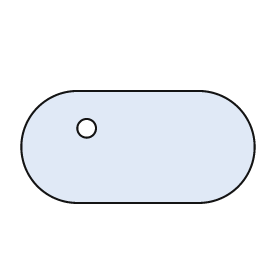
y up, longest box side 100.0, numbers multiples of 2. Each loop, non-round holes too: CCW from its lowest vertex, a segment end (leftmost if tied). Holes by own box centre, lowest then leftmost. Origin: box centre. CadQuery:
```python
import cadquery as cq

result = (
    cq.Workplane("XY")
    .moveTo(-26.0, -24.0)
    .lineTo(26.0, -24.0)
    .threePointArc((50.0, 0.0), (26.0, 24.0))
    .lineTo(-26.0, 24.0)
    .threePointArc((-50.0, 0.0), (-26.0, -24.0))
    .close()
    .moveTo(-22.0, 8.0)
    .circle(4.0)
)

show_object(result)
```